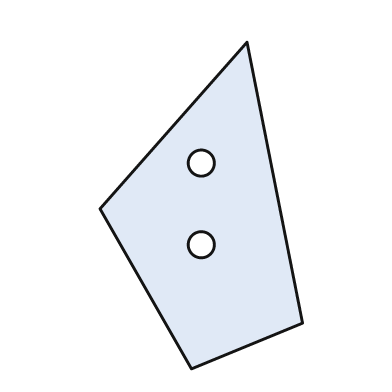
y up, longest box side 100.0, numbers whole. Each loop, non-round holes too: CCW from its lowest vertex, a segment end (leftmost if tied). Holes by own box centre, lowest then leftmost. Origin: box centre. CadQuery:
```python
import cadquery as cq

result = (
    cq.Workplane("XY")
    .moveTo(-3.0, -50.0)
    .lineTo(31.0, -36.0)
    .lineTo(14.0, 50.0)
    .lineTo(-31.0, -1.0)
    .close()
    .moveTo(0.0, -12.0)
    .circle(4.0)
    .moveTo(0.0, 13.0)
    .circle(4.0)
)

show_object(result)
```